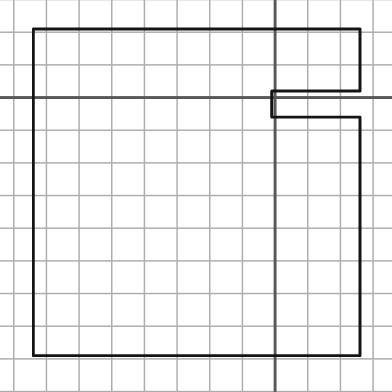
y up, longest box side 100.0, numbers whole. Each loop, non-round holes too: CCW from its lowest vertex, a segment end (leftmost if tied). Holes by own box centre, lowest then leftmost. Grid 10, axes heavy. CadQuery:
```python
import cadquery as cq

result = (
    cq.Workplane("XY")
    .moveTo(-74.0, -79.0)
    .lineTo(26.0, -79.0)
    .lineTo(26.0, -6.0)
    .lineTo(-1.0, -6.0)
    .lineTo(-1.0, 2.0)
    .lineTo(26.0, 2.0)
    .lineTo(26.0, 21.0)
    .lineTo(-74.0, 21.0)
    .close()
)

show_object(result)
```